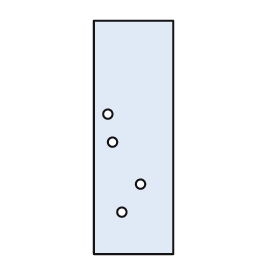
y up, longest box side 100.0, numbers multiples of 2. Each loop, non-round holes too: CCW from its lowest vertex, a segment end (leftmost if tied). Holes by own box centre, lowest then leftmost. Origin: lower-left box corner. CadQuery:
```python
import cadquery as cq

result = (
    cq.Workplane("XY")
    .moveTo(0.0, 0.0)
    .lineTo(34.0, 0.0)
    .lineTo(34.0, 100.0)
    .lineTo(0.0, 100.0)
    .close()
    .moveTo(12.0, 18.0)
    .circle(2.0)
    .moveTo(20.0, 30.0)
    .circle(2.0)
    .moveTo(8.0, 48.0)
    .circle(2.0)
    .moveTo(6.0, 60.0)
    .circle(2.0)
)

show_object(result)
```